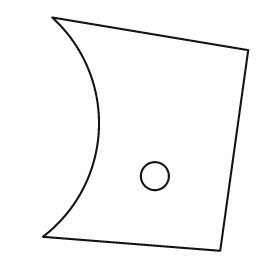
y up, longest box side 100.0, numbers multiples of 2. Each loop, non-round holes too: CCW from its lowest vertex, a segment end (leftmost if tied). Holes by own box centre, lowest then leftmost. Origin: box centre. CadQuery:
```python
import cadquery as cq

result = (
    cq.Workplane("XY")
    .moveTo(32.0, -50.0)
    .lineTo(44.0, 36.0)
    .lineTo(-40.0, 50.0)
    .threePointArc((-20.0, 2.0), (-44.0, -44.0))
    .close()
    .moveTo(4.0, -18.0)
    .circle(6.0)
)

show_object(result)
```